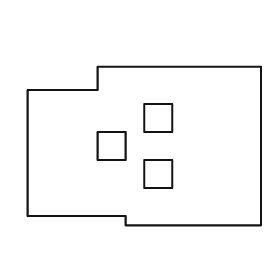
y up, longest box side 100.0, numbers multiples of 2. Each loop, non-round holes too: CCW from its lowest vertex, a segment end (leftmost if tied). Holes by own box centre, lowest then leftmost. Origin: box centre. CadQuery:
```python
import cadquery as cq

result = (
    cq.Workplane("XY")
    .moveTo(-8.0, -34.0)
    .lineTo(50.0, -34.0)
    .lineTo(50.0, 34.0)
    .lineTo(-20.0, 34.0)
    .lineTo(-20.0, 24.0)
    .lineTo(-50.0, 24.0)
    .lineTo(-50.0, -30.0)
    .lineTo(-8.0, -30.0)
    .close()
    .moveTo(0.0, -18.0)
    .lineTo(12.0, -18.0)
    .lineTo(12.0, -6.0)
    .lineTo(0.0, -6.0)
    .close()
    .moveTo(-20.0, -6.0)
    .lineTo(-8.0, -6.0)
    .lineTo(-8.0, 6.0)
    .lineTo(-20.0, 6.0)
    .close()
    .moveTo(0.0, 6.0)
    .lineTo(12.0, 6.0)
    .lineTo(12.0, 18.0)
    .lineTo(0.0, 18.0)
    .close()
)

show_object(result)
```